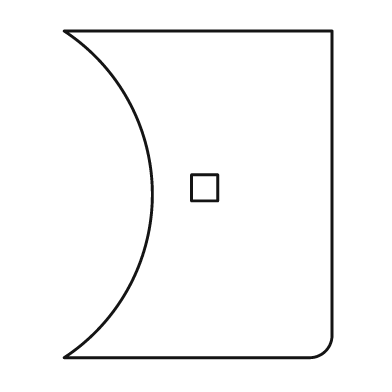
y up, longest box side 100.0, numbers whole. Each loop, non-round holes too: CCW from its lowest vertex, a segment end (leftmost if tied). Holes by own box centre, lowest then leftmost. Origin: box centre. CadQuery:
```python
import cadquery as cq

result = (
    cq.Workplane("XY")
    .moveTo(-41.0, -50.0)
    .lineTo(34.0, -50.0)
    .threePointArc((39.0, -48.0), (41.0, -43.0))
    .lineTo(41.0, 50.0)
    .lineTo(-41.0, 50.0)
    .threePointArc((-14.0, 0.0), (-41.0, -50.0))
    .close()
    .moveTo(-2.0, -2.0)
    .lineTo(6.0, -2.0)
    .lineTo(6.0, 6.0)
    .lineTo(-2.0, 6.0)
    .close()
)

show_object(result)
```